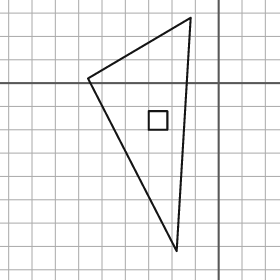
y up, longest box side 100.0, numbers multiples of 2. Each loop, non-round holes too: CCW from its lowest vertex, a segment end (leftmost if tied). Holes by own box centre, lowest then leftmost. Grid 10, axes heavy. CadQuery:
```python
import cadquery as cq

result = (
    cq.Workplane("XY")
    .moveTo(-18.0, -72.0)
    .lineTo(-12.0, 28.0)
    .lineTo(-56.0, 2.0)
    .close()
    .moveTo(-30.0, -20.0)
    .lineTo(-22.0, -20.0)
    .lineTo(-22.0, -12.0)
    .lineTo(-30.0, -12.0)
    .close()
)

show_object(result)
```